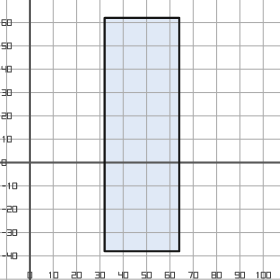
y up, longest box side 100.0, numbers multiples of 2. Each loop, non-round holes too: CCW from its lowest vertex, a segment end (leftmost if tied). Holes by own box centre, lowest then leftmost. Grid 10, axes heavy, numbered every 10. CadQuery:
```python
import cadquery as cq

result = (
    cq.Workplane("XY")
    .moveTo(32.0, -38.0)
    .lineTo(64.0, -38.0)
    .lineTo(64.0, 62.0)
    .lineTo(32.0, 62.0)
    .close()
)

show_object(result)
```